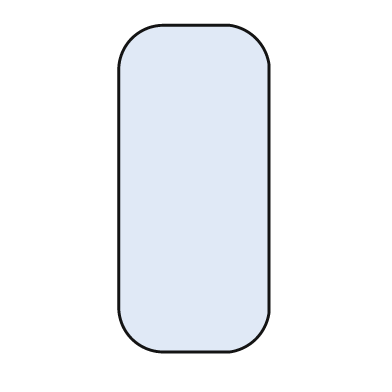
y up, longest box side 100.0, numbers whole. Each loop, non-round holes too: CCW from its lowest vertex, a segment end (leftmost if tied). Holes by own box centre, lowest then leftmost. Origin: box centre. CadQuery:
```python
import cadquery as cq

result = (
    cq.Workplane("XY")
    .moveTo(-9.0, -50.0)
    .lineTo(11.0, -50.0)
    .threePointArc((19.0, -46.0), (23.0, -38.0))
    .lineTo(23.0, 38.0)
    .threePointArc((19.0, 46.0), (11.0, 50.0))
    .lineTo(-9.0, 50.0)
    .threePointArc((-19.0, 46.0), (-23.0, 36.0))
    .lineTo(-23.0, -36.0)
    .threePointArc((-19.0, -46.0), (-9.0, -50.0))
    .close()
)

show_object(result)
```